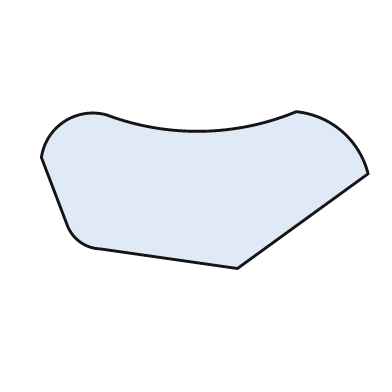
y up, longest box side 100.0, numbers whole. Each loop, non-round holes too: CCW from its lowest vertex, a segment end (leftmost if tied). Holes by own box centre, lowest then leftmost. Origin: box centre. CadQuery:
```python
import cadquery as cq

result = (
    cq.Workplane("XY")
    .moveTo(10.0, -24.0)
    .lineTo(50.0, 5.0)
    .threePointArc((42.0, 18.0), (28.0, 24.0))
    .threePointArc((-1.0, 18.0), (-30.0, 23.0))
    .threePointArc((-43.0, 21.0), (-50.0, 10.0))
    .lineTo(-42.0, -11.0)
    .threePointArc((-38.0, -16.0), (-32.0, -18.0))
    .close()
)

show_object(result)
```